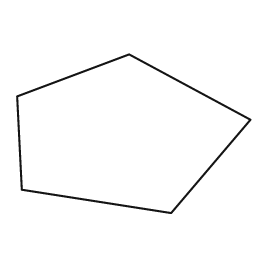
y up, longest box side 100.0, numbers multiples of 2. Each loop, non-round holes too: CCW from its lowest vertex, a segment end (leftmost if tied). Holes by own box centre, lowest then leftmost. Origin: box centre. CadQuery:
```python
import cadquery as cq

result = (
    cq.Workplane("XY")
    .moveTo(16.0, -34.0)
    .lineTo(50.0, 6.0)
    .lineTo(-2.0, 34.0)
    .lineTo(-50.0, 16.0)
    .lineTo(-48.0, -24.0)
    .close()
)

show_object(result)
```